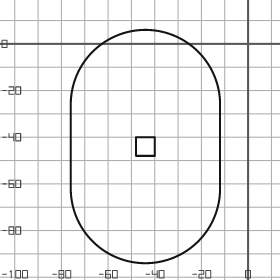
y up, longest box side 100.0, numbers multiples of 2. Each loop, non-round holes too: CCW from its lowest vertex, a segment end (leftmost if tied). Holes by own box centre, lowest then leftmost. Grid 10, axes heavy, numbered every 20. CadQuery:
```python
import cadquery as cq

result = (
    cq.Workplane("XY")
    .moveTo(-76.0, -62.0)
    .threePointArc((-44.0, -94.0), (-12.0, -62.0))
    .lineTo(-12.0, -26.0)
    .threePointArc((-44.0, 6.0), (-76.0, -26.0))
    .close()
    .moveTo(-48.0, -48.0)
    .lineTo(-40.0, -48.0)
    .lineTo(-40.0, -40.0)
    .lineTo(-48.0, -40.0)
    .close()
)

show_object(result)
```